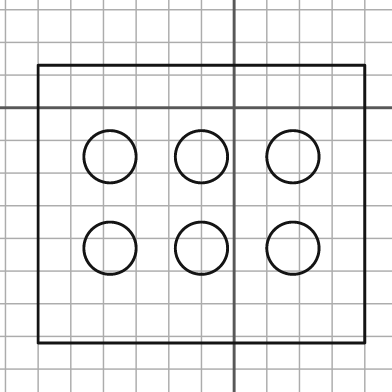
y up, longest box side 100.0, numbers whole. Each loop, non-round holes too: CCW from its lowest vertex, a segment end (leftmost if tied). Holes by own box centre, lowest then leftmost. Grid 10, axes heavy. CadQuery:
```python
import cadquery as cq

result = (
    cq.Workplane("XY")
    .moveTo(-60.0, -72.0)
    .lineTo(40.0, -72.0)
    .lineTo(40.0, 13.0)
    .lineTo(-60.0, 13.0)
    .close()
    .moveTo(-38.0, -43.0)
    .circle(8.0)
    .moveTo(-10.0, -43.0)
    .circle(8.0)
    .moveTo(18.0, -43.0)
    .circle(8.0)
    .moveTo(-38.0, -15.0)
    .circle(8.0)
    .moveTo(-10.0, -15.0)
    .circle(8.0)
    .moveTo(18.0, -15.0)
    .circle(8.0)
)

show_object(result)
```